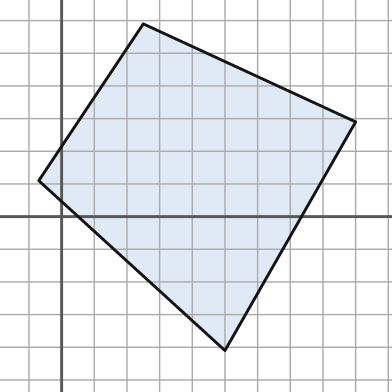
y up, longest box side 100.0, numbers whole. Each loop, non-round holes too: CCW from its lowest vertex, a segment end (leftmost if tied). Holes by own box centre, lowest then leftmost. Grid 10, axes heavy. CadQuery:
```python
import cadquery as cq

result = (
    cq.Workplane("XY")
    .moveTo(50.0, -41.0)
    .lineTo(90.0, 29.0)
    .lineTo(25.0, 59.0)
    .lineTo(-7.0, 11.0)
    .close()
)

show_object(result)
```